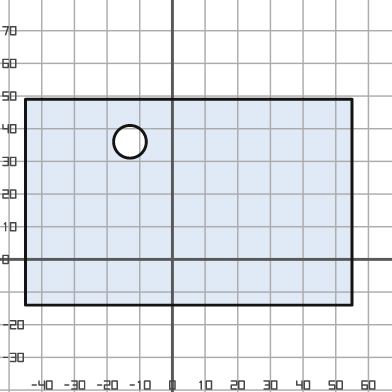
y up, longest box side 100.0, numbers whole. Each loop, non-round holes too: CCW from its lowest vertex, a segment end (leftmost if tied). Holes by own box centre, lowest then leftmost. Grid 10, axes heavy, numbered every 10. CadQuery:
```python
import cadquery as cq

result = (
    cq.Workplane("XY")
    .moveTo(-45.0, -14.0)
    .lineTo(55.0, -14.0)
    .lineTo(55.0, 49.0)
    .lineTo(-45.0, 49.0)
    .close()
    .moveTo(-13.0, 36.0)
    .circle(5.0)
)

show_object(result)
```